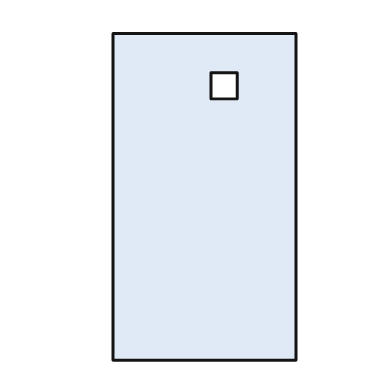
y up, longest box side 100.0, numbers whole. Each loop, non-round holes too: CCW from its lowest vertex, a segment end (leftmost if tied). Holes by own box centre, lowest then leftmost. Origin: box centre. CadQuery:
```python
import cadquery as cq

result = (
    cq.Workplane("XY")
    .moveTo(-28.0, -50.0)
    .lineTo(28.0, -50.0)
    .lineTo(28.0, 50.0)
    .lineTo(-28.0, 50.0)
    .close()
    .moveTo(2.0, 30.0)
    .lineTo(10.0, 30.0)
    .lineTo(10.0, 38.0)
    .lineTo(2.0, 38.0)
    .close()
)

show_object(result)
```